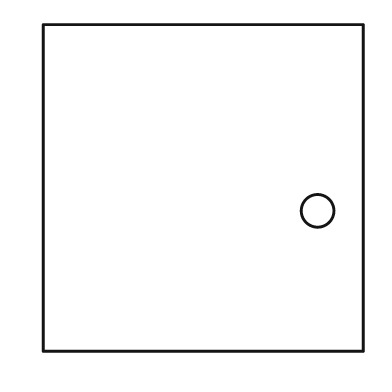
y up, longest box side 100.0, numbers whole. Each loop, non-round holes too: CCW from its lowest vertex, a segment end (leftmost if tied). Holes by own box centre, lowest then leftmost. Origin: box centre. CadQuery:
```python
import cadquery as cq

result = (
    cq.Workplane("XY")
    .moveTo(-49.0, -50.0)
    .lineTo(49.0, -50.0)
    .lineTo(49.0, 50.0)
    .lineTo(-49.0, 50.0)
    .close()
    .moveTo(35.0, -7.0)
    .circle(5.0)
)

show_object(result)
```